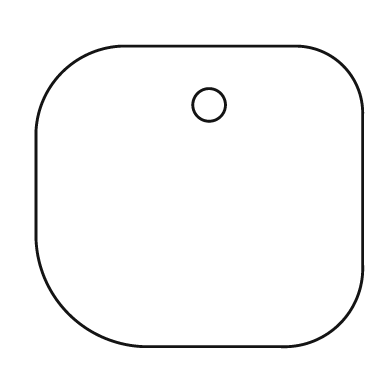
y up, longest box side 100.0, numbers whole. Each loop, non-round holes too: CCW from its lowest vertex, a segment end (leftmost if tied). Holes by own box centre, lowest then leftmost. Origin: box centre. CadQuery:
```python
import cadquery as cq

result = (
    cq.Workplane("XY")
    .moveTo(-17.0, -46.0)
    .lineTo(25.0, -46.0)
    .threePointArc((43.0, -39.0), (50.0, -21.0))
    .lineTo(50.0, 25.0)
    .threePointArc((44.0, 40.0), (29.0, 46.0))
    .lineTo(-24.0, 46.0)
    .threePointArc((-42.0, 38.0), (-50.0, 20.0))
    .lineTo(-50.0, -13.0)
    .threePointArc((-40.0, -36.0), (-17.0, -46.0))
    .close()
    .moveTo(3.0, 28.0)
    .circle(5.0)
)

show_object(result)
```